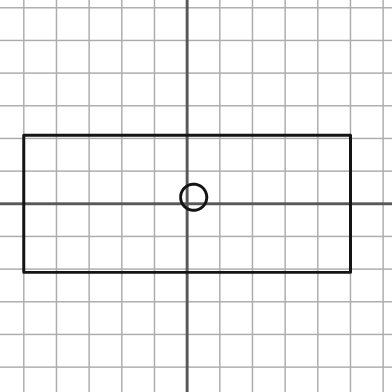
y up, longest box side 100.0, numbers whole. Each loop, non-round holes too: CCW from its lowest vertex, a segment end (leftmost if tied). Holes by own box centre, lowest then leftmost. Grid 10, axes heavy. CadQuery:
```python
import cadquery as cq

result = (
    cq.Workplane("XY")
    .moveTo(-50.0, -21.0)
    .lineTo(50.0, -21.0)
    .lineTo(50.0, 21.0)
    .lineTo(-50.0, 21.0)
    .close()
    .moveTo(2.0, 2.0)
    .circle(4.0)
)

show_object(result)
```